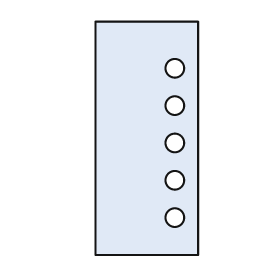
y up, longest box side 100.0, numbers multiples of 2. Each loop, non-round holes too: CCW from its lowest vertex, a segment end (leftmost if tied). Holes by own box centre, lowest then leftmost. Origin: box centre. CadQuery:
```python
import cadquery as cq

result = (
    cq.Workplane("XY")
    .moveTo(-22.0, -50.0)
    .lineTo(22.0, -50.0)
    .lineTo(22.0, 50.0)
    .lineTo(-22.0, 50.0)
    .close()
    .moveTo(12.0, -34.0)
    .circle(4.0)
    .moveTo(12.0, -18.0)
    .circle(4.0)
    .moveTo(12.0, -2.0)
    .circle(4.0)
    .moveTo(12.0, 14.0)
    .circle(4.0)
    .moveTo(12.0, 30.0)
    .circle(4.0)
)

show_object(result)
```